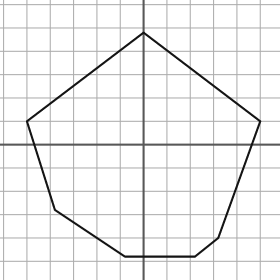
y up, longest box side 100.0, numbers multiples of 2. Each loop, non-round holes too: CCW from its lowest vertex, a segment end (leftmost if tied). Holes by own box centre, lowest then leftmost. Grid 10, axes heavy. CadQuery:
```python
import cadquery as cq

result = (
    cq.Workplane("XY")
    .moveTo(-8.0, -48.0)
    .lineTo(22.0, -48.0)
    .lineTo(32.0, -40.0)
    .lineTo(50.0, 10.0)
    .lineTo(0.0, 48.0)
    .lineTo(-50.0, 10.0)
    .lineTo(-38.0, -28.0)
    .close()
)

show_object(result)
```